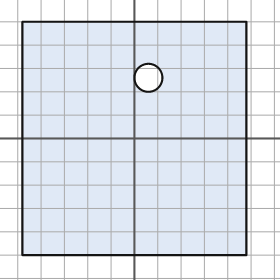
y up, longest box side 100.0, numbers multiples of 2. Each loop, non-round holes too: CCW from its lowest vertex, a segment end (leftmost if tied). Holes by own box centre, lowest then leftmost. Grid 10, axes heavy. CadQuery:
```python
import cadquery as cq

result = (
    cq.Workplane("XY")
    .moveTo(-48.0, -50.0)
    .lineTo(48.0, -50.0)
    .lineTo(48.0, 50.0)
    .lineTo(-48.0, 50.0)
    .close()
    .moveTo(6.0, 26.0)
    .circle(6.0)
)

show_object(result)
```